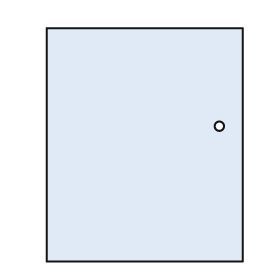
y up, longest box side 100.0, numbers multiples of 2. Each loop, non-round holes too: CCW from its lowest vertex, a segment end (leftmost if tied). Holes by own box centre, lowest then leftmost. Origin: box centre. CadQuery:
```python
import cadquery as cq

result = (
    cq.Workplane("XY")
    .moveTo(-42.0, -50.0)
    .lineTo(42.0, -50.0)
    .lineTo(42.0, 50.0)
    .lineTo(-42.0, 50.0)
    .close()
    .moveTo(32.0, 8.0)
    .circle(2.0)
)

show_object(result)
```